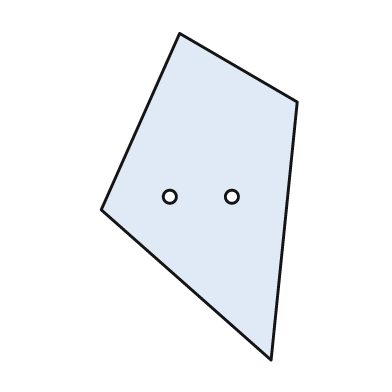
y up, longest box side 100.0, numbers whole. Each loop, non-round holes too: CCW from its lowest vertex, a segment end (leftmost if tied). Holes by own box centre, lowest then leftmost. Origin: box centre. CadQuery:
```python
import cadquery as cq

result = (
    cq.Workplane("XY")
    .moveTo(22.0, -50.0)
    .lineTo(30.0, 29.0)
    .lineTo(-6.0, 50.0)
    .lineTo(-30.0, -4.0)
    .close()
    .moveTo(-9.0, 0.0)
    .circle(2.0)
    .moveTo(10.0, 0.0)
    .circle(2.0)
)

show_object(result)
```